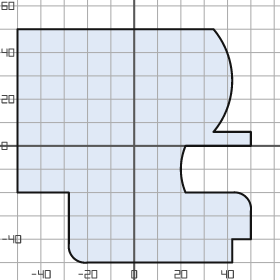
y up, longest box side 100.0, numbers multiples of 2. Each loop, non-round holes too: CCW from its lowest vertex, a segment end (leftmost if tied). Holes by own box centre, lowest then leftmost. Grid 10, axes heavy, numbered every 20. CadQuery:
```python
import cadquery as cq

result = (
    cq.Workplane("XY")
    .moveTo(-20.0, -50.0)
    .lineTo(42.0, -50.0)
    .lineTo(42.0, -40.0)
    .lineTo(50.0, -40.0)
    .lineTo(50.0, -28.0)
    .threePointArc((48.0, -22.0), (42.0, -20.0))
    .lineTo(22.0, -20.0)
    .threePointArc((20.0, -10.0), (22.0, 0.0))
    .lineTo(50.0, 0.0)
    .lineTo(50.0, 6.0)
    .lineTo(34.0, 6.0)
    .threePointArc((42.0, 28.0), (34.0, 50.0))
    .lineTo(-50.0, 50.0)
    .lineTo(-50.0, -20.0)
    .lineTo(-28.0, -20.0)
    .lineTo(-28.0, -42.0)
    .threePointArc((-26.0, -48.0), (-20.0, -50.0))
    .close()
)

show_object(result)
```